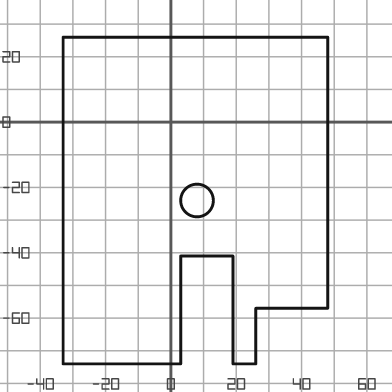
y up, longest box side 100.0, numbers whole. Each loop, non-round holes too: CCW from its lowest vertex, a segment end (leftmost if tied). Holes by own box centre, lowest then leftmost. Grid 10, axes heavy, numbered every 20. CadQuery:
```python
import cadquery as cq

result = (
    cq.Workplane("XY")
    .moveTo(-33.0, -74.0)
    .lineTo(3.0, -74.0)
    .lineTo(3.0, -41.0)
    .lineTo(19.0, -41.0)
    .lineTo(19.0, -74.0)
    .lineTo(26.0, -74.0)
    .lineTo(26.0, -57.0)
    .lineTo(48.0, -57.0)
    .lineTo(48.0, 26.0)
    .lineTo(-33.0, 26.0)
    .close()
    .moveTo(8.0, -24.0)
    .circle(5.0)
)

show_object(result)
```